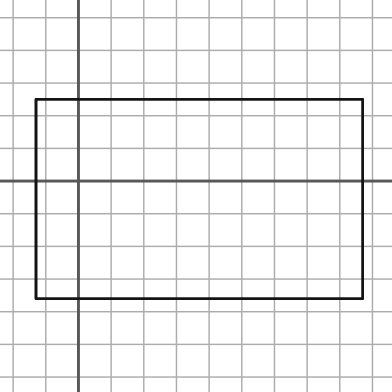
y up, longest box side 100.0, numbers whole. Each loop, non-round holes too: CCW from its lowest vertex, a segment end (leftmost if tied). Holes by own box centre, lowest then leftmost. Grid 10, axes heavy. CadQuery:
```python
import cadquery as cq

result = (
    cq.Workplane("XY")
    .moveTo(-13.0, -36.0)
    .lineTo(87.0, -36.0)
    .lineTo(87.0, 25.0)
    .lineTo(-13.0, 25.0)
    .close()
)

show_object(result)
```